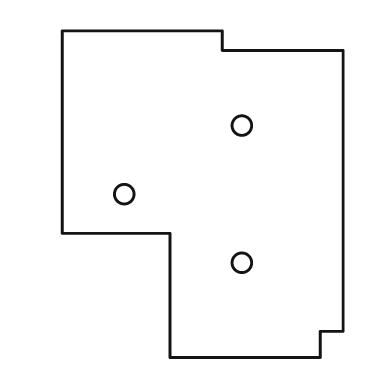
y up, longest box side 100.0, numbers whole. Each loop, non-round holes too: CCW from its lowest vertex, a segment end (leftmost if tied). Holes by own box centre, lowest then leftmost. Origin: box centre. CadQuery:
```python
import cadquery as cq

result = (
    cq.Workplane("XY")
    .moveTo(-10.0, -50.0)
    .lineTo(36.0, -50.0)
    .lineTo(36.0, -42.0)
    .lineTo(43.0, -42.0)
    .lineTo(43.0, 44.0)
    .lineTo(6.0, 44.0)
    .lineTo(6.0, 50.0)
    .lineTo(-43.0, 50.0)
    .lineTo(-43.0, -12.0)
    .lineTo(-10.0, -12.0)
    .close()
    .moveTo(12.0, -21.0)
    .circle(3.0)
    .moveTo(-24.0, 0.0)
    .circle(3.0)
    .moveTo(12.0, 21.0)
    .circle(3.0)
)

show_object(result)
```